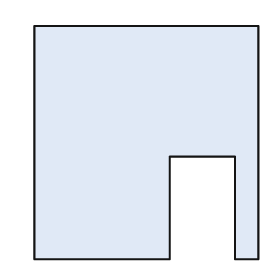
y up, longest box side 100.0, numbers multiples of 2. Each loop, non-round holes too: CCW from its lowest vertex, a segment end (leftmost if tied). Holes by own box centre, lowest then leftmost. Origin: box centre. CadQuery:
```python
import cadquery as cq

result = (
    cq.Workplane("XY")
    .moveTo(-48.0, -50.0)
    .lineTo(10.0, -50.0)
    .lineTo(10.0, -6.0)
    .lineTo(38.0, -6.0)
    .lineTo(38.0, -50.0)
    .lineTo(48.0, -50.0)
    .lineTo(48.0, 50.0)
    .lineTo(-48.0, 50.0)
    .close()
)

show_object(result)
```